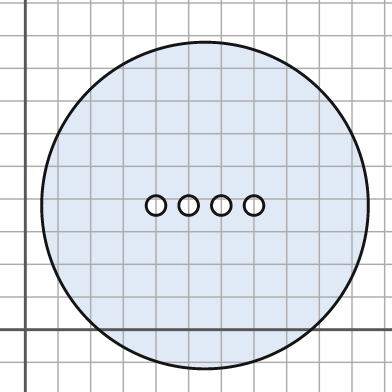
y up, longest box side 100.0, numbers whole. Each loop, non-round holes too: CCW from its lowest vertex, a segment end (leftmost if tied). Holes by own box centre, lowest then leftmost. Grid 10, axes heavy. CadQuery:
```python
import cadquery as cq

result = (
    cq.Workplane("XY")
    .moveTo(55.0, 38.0)
    .circle(50.0)
    .moveTo(40.0, 38.0)
    .circle(3.0)
    .moveTo(50.0, 38.0)
    .circle(3.0)
    .moveTo(60.0, 38.0)
    .circle(3.0)
    .moveTo(70.0, 38.0)
    .circle(3.0)
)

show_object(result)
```